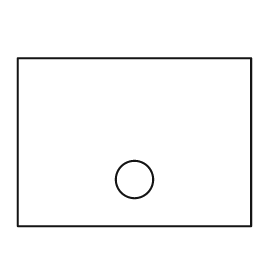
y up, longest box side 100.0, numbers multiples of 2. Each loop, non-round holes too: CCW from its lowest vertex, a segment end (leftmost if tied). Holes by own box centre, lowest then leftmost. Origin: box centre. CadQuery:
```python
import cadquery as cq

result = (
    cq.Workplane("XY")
    .moveTo(-50.0, -36.0)
    .lineTo(50.0, -36.0)
    .lineTo(50.0, 36.0)
    .lineTo(-50.0, 36.0)
    .close()
    .moveTo(0.0, -16.0)
    .circle(8.0)
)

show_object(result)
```